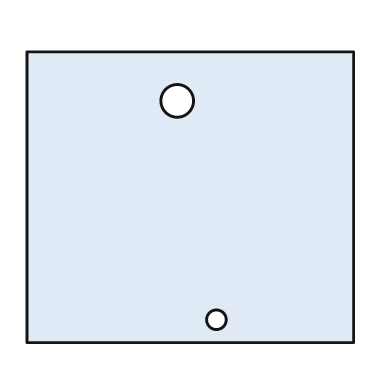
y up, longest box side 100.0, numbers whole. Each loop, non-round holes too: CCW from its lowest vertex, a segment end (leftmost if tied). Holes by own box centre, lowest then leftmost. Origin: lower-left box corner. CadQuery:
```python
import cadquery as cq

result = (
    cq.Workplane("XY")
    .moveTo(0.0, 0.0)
    .lineTo(100.0, 0.0)
    .lineTo(100.0, 89.0)
    .lineTo(0.0, 89.0)
    .close()
    .moveTo(58.0, 7.0)
    .circle(3.0)
    .moveTo(46.0, 74.0)
    .circle(5.0)
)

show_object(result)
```